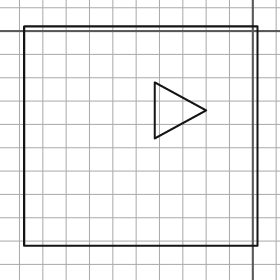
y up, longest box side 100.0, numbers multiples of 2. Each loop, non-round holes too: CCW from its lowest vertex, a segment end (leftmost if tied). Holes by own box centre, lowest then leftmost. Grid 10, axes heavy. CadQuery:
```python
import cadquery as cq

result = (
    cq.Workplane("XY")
    .moveTo(-98.0, -92.0)
    .lineTo(2.0, -92.0)
    .lineTo(2.0, 2.0)
    .lineTo(-98.0, 2.0)
    .close()
    .moveTo(-42.0, -46.0)
    .lineTo(-20.0, -34.0)
    .lineTo(-42.0, -22.0)
    .close()
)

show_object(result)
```